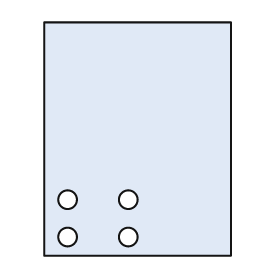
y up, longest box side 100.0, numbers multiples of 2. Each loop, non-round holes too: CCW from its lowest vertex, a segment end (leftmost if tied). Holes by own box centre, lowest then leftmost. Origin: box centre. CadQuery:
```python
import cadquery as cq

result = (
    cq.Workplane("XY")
    .moveTo(-40.0, -50.0)
    .lineTo(40.0, -50.0)
    .lineTo(40.0, 50.0)
    .lineTo(-40.0, 50.0)
    .close()
    .moveTo(-30.0, -42.0)
    .circle(4.0)
    .moveTo(-4.0, -42.0)
    .circle(4.0)
    .moveTo(-30.0, -26.0)
    .circle(4.0)
    .moveTo(-4.0, -26.0)
    .circle(4.0)
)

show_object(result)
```